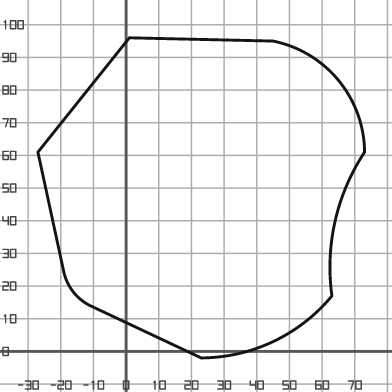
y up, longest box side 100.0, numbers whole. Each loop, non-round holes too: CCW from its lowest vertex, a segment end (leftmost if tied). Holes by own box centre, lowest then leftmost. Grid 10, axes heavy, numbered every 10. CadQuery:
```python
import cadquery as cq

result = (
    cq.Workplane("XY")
    .moveTo(23.0, -2.0)
    .threePointArc((45.0, 3.0), (63.0, 17.0))
    .threePointArc((64.0, 40.0), (73.0, 61.0))
    .threePointArc((65.0, 83.0), (45.0, 95.0))
    .lineTo(1.0, 96.0)
    .lineTo(-27.0, 61.0)
    .lineTo(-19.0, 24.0)
    .threePointArc((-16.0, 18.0), (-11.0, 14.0))
    .close()
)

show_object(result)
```